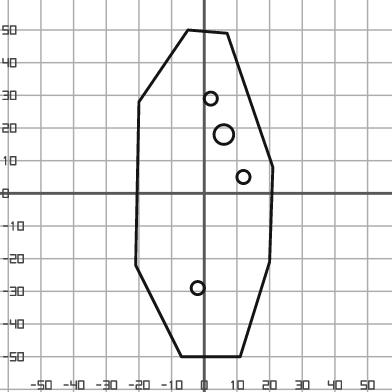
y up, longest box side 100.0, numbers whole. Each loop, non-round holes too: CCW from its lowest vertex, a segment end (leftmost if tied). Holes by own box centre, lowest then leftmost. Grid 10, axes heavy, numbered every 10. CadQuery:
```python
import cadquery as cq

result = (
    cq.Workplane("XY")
    .moveTo(-7.0, -50.0)
    .lineTo(11.0, -50.0)
    .lineTo(20.0, -21.0)
    .lineTo(21.0, 8.0)
    .lineTo(7.0, 49.0)
    .lineTo(-5.0, 50.0)
    .lineTo(-20.0, 28.0)
    .lineTo(-21.0, -22.0)
    .close()
    .moveTo(-2.0, -29.0)
    .circle(2.0)
    .moveTo(12.0, 5.0)
    .circle(2.0)
    .moveTo(6.0, 18.0)
    .circle(3.0)
    .moveTo(2.0, 29.0)
    .circle(2.0)
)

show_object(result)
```